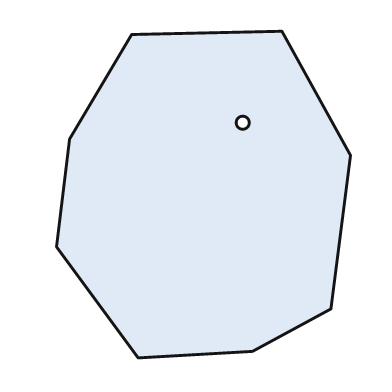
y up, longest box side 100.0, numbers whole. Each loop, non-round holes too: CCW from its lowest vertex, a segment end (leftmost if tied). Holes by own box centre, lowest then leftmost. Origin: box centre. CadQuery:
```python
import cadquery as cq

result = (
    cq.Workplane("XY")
    .moveTo(-20.0, -50.0)
    .lineTo(15.0, -48.0)
    .lineTo(39.0, -35.0)
    .lineTo(45.0, 12.0)
    .lineTo(24.0, 50.0)
    .lineTo(-22.0, 49.0)
    .lineTo(-41.0, 17.0)
    .lineTo(-45.0, -16.0)
    .close()
    .moveTo(12.0, 22.0)
    .circle(2.0)
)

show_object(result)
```